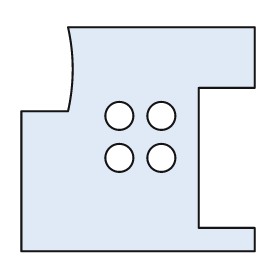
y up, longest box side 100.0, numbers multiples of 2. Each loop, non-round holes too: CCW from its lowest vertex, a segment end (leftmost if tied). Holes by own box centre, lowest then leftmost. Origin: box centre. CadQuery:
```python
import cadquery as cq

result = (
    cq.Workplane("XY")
    .moveTo(-50.0, -48.0)
    .lineTo(50.0, -48.0)
    .lineTo(50.0, -38.0)
    .lineTo(26.0, -38.0)
    .lineTo(26.0, 22.0)
    .lineTo(50.0, 22.0)
    .lineTo(50.0, 48.0)
    .lineTo(-30.0, 48.0)
    .threePointArc((-28.0, 30.0), (-30.0, 12.0))
    .lineTo(-50.0, 12.0)
    .close()
    .moveTo(-8.0, -8.0)
    .circle(6.0)
    .moveTo(10.0, -8.0)
    .circle(6.0)
    .moveTo(-8.0, 10.0)
    .circle(6.0)
    .moveTo(10.0, 10.0)
    .circle(6.0)
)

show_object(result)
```